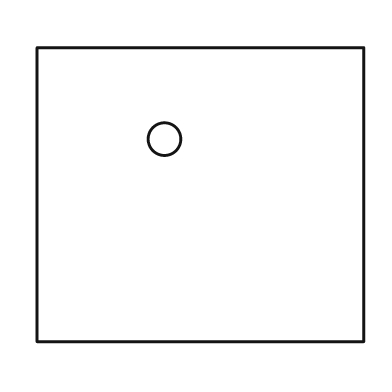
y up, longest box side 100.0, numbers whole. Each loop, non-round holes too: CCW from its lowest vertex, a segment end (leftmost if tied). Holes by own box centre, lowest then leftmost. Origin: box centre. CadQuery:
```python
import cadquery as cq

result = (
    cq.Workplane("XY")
    .moveTo(-50.0, -45.0)
    .lineTo(50.0, -45.0)
    .lineTo(50.0, 45.0)
    .lineTo(-50.0, 45.0)
    .close()
    .moveTo(-11.0, 17.0)
    .circle(5.0)
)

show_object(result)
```